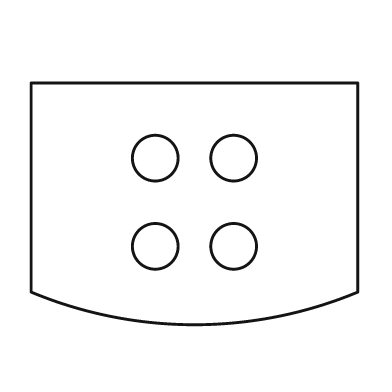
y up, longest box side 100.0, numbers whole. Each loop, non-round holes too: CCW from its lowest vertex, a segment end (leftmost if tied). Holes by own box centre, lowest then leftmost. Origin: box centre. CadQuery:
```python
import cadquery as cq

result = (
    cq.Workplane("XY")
    .moveTo(-50.0, -27.0)
    .threePointArc((0.0, -37.0), (50.0, -27.0))
    .lineTo(50.0, 37.0)
    .lineTo(-50.0, 37.0)
    .close()
    .moveTo(-12.0, -13.0)
    .circle(7.0)
    .moveTo(12.0, -13.0)
    .circle(7.0)
    .moveTo(-12.0, 14.0)
    .circle(7.0)
    .moveTo(12.0, 14.0)
    .circle(7.0)
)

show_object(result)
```